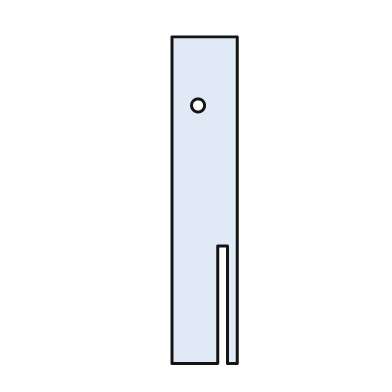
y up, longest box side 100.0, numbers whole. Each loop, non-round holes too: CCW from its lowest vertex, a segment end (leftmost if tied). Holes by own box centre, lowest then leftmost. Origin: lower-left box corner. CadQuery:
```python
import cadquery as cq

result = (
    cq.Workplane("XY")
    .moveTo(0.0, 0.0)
    .lineTo(14.0, 0.0)
    .lineTo(14.0, 36.0)
    .lineTo(17.0, 36.0)
    .lineTo(17.0, 0.0)
    .lineTo(20.0, 0.0)
    .lineTo(20.0, 100.0)
    .lineTo(0.0, 100.0)
    .close()
    .moveTo(8.0, 79.0)
    .circle(2.0)
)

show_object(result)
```